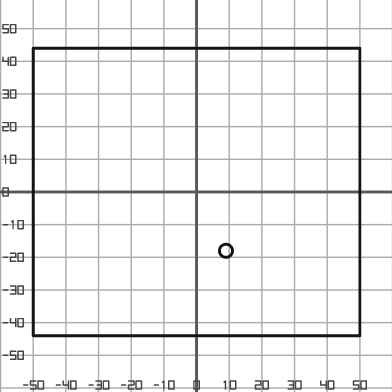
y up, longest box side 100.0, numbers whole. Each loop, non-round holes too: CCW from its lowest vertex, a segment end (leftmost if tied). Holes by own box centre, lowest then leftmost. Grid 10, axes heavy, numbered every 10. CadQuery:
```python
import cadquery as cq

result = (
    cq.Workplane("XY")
    .moveTo(-50.0, -44.0)
    .lineTo(50.0, -44.0)
    .lineTo(50.0, 44.0)
    .lineTo(-50.0, 44.0)
    .close()
    .moveTo(9.0, -18.0)
    .circle(2.0)
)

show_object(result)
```